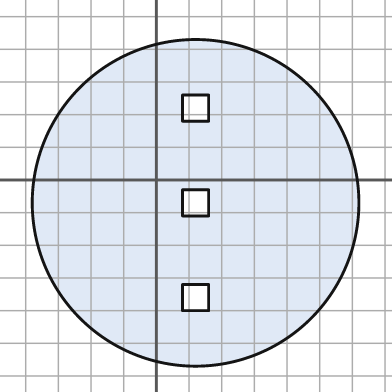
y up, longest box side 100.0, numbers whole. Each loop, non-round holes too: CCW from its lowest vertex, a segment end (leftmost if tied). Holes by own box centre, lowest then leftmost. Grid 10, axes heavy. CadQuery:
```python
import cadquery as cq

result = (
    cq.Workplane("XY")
    .moveTo(12.0, -7.0)
    .circle(50.0)
    .moveTo(8.0, -40.0)
    .lineTo(16.0, -40.0)
    .lineTo(16.0, -32.0)
    .lineTo(8.0, -32.0)
    .close()
    .moveTo(8.0, -11.0)
    .lineTo(16.0, -11.0)
    .lineTo(16.0, -3.0)
    .lineTo(8.0, -3.0)
    .close()
    .moveTo(8.0, 18.0)
    .lineTo(16.0, 18.0)
    .lineTo(16.0, 26.0)
    .lineTo(8.0, 26.0)
    .close()
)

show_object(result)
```